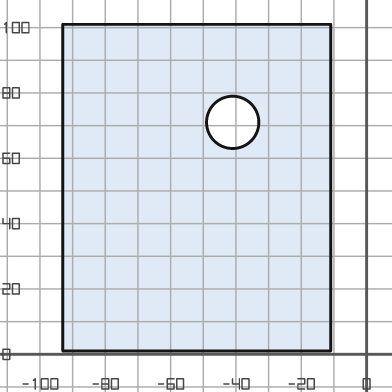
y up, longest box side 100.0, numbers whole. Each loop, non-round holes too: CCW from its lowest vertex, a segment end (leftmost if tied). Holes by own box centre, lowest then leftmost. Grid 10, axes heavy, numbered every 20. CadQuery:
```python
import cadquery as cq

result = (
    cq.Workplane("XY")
    .moveTo(-93.0, 1.0)
    .lineTo(-11.0, 1.0)
    .lineTo(-11.0, 101.0)
    .lineTo(-93.0, 101.0)
    .close()
    .moveTo(-41.0, 71.0)
    .circle(8.0)
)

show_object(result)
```